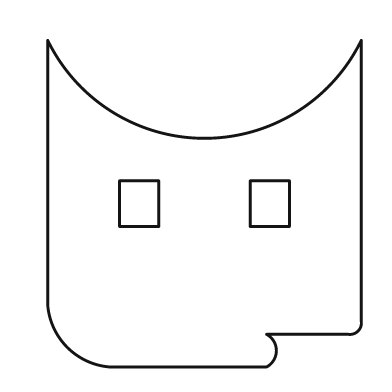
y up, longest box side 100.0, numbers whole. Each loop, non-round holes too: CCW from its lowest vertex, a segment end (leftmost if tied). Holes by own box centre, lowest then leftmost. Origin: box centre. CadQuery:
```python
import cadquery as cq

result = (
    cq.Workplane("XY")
    .moveTo(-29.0, -50.0)
    .lineTo(19.0, -50.0)
    .threePointArc((22.0, -45.0), (19.0, -40.0))
    .lineTo(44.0, -40.0)
    .threePointArc((47.0, -39.0), (48.0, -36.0))
    .lineTo(48.0, 50.0)
    .threePointArc((0.0, 20.0), (-48.0, 50.0))
    .lineTo(-48.0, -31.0)
    .threePointArc((-42.0, -44.0), (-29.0, -50.0))
    .close()
    .moveTo(-26.0, -7.0)
    .lineTo(-14.0, -7.0)
    .lineTo(-14.0, 7.0)
    .lineTo(-26.0, 7.0)
    .close()
    .moveTo(14.0, -7.0)
    .lineTo(26.0, -7.0)
    .lineTo(26.0, 7.0)
    .lineTo(14.0, 7.0)
    .close()
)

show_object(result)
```